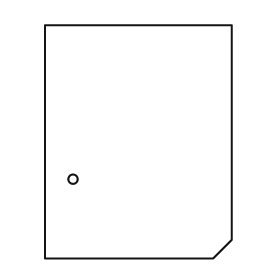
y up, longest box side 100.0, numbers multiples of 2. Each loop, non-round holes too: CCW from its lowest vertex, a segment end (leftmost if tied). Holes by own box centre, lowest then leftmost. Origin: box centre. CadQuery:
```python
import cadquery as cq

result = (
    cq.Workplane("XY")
    .moveTo(-40.0, -50.0)
    .lineTo(32.0, -50.0)
    .lineTo(40.0, -42.0)
    .lineTo(40.0, 50.0)
    .lineTo(-40.0, 50.0)
    .close()
    .moveTo(-28.0, -16.0)
    .circle(2.0)
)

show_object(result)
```